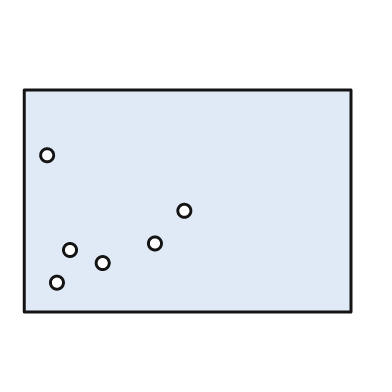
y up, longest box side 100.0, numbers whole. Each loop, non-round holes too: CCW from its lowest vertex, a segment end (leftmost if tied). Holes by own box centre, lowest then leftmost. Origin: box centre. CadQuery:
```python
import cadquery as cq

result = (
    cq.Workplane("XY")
    .moveTo(-50.0, -34.0)
    .lineTo(50.0, -34.0)
    .lineTo(50.0, 34.0)
    .lineTo(-50.0, 34.0)
    .close()
    .moveTo(-40.0, -25.0)
    .circle(2.0)
    .moveTo(-26.0, -19.0)
    .circle(2.0)
    .moveTo(-36.0, -15.0)
    .circle(2.0)
    .moveTo(-10.0, -13.0)
    .circle(2.0)
    .moveTo(-1.0, -3.0)
    .circle(2.0)
    .moveTo(-43.0, 14.0)
    .circle(2.0)
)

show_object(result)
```